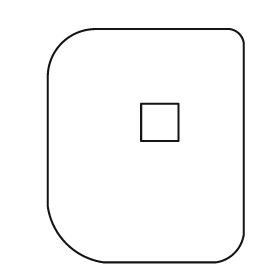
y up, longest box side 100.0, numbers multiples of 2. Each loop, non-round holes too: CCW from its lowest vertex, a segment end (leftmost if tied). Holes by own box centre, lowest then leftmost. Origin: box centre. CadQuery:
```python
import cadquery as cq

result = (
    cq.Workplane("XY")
    .moveTo(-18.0, -50.0)
    .lineTo(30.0, -50.0)
    .threePointArc((38.0, -46.0), (42.0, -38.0))
    .lineTo(42.0, 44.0)
    .threePointArc((40.0, 48.0), (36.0, 50.0))
    .lineTo(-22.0, 50.0)
    .threePointArc((-36.0, 44.0), (-42.0, 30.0))
    .lineTo(-42.0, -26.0)
    .threePointArc((-34.0, -42.0), (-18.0, -50.0))
    .close()
    .moveTo(-2.0, 2.0)
    .lineTo(14.0, 2.0)
    .lineTo(14.0, 18.0)
    .lineTo(-2.0, 18.0)
    .close()
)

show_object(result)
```